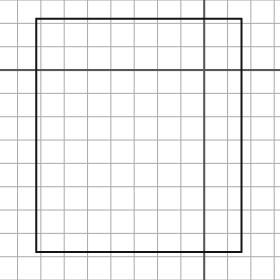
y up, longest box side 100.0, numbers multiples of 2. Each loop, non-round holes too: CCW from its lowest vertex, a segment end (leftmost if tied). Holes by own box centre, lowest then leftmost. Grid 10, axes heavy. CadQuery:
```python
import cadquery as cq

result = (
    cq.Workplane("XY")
    .moveTo(-72.0, -78.0)
    .lineTo(16.0, -78.0)
    .lineTo(16.0, 22.0)
    .lineTo(-72.0, 22.0)
    .close()
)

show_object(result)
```